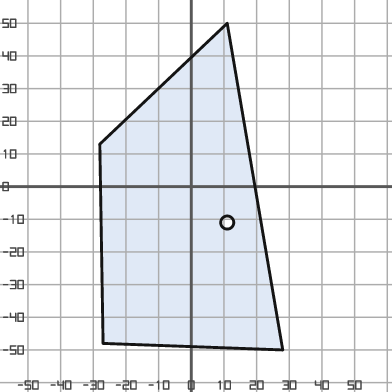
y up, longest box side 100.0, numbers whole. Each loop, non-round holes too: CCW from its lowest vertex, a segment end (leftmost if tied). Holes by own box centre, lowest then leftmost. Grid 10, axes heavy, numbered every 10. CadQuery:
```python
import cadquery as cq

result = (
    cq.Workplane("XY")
    .moveTo(28.0, -50.0)
    .lineTo(11.0, 50.0)
    .lineTo(-28.0, 13.0)
    .lineTo(-27.0, -48.0)
    .close()
    .moveTo(11.0, -11.0)
    .circle(2.0)
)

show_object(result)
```